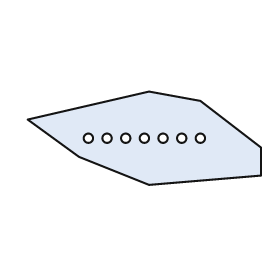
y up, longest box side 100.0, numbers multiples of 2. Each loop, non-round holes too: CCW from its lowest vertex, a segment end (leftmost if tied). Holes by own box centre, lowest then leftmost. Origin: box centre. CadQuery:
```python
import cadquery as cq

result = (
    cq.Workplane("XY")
    .moveTo(2.0, -20.0)
    .lineTo(50.0, -16.0)
    .lineTo(50.0, -4.0)
    .lineTo(24.0, 16.0)
    .lineTo(2.0, 20.0)
    .lineTo(-50.0, 8.0)
    .lineTo(-28.0, -8.0)
    .close()
    .moveTo(-24.0, 0.0)
    .circle(2.0)
    .moveTo(-16.0, 0.0)
    .circle(2.0)
    .moveTo(-8.0, 0.0)
    .circle(2.0)
    .moveTo(0.0, 0.0)
    .circle(2.0)
    .moveTo(8.0, 0.0)
    .circle(2.0)
    .moveTo(16.0, 0.0)
    .circle(2.0)
    .moveTo(24.0, 0.0)
    .circle(2.0)
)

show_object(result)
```